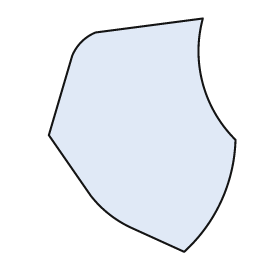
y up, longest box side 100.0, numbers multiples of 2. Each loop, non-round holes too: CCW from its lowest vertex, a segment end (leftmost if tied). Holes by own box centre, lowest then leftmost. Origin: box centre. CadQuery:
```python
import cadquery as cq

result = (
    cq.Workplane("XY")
    .moveTo(18.0, -50.0)
    .threePointArc((34.0, -28.0), (40.0, -2.0))
    .threePointArc((26.0, 22.0), (26.0, 50.0))
    .lineTo(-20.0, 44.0)
    .threePointArc((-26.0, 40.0), (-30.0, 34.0))
    .lineTo(-40.0, 0.0)
    .lineTo(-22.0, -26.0)
    .threePointArc((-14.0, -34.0), (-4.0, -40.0))
    .close()
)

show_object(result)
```